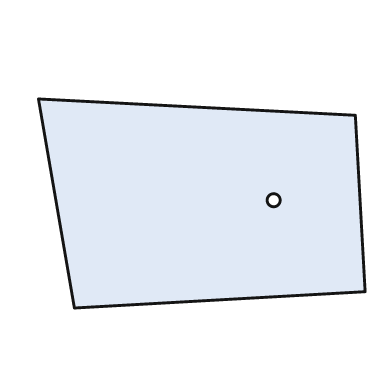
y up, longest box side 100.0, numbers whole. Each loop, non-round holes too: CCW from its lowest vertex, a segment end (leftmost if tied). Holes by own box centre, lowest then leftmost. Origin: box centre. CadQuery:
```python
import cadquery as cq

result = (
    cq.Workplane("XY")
    .moveTo(-39.0, -32.0)
    .lineTo(50.0, -27.0)
    .lineTo(47.0, 27.0)
    .lineTo(-50.0, 32.0)
    .close()
    .moveTo(22.0, 1.0)
    .circle(2.0)
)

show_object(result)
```